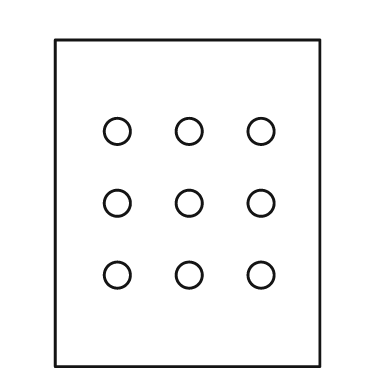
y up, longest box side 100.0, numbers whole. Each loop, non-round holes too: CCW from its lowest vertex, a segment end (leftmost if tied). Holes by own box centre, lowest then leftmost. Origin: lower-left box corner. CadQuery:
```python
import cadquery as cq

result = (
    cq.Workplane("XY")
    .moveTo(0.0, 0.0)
    .lineTo(81.0, 0.0)
    .lineTo(81.0, 100.0)
    .lineTo(0.0, 100.0)
    .close()
    .moveTo(19.0, 28.0)
    .circle(4.0)
    .moveTo(41.0, 28.0)
    .circle(4.0)
    .moveTo(63.0, 28.0)
    .circle(4.0)
    .moveTo(19.0, 50.0)
    .circle(4.0)
    .moveTo(41.0, 50.0)
    .circle(4.0)
    .moveTo(63.0, 50.0)
    .circle(4.0)
    .moveTo(19.0, 72.0)
    .circle(4.0)
    .moveTo(41.0, 72.0)
    .circle(4.0)
    .moveTo(63.0, 72.0)
    .circle(4.0)
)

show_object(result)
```